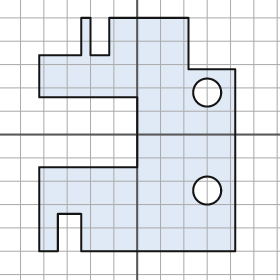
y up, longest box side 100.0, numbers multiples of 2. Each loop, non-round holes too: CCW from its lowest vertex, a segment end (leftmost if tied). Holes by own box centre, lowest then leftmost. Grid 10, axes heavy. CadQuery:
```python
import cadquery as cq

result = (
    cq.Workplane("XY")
    .moveTo(-42.0, -50.0)
    .lineTo(-34.0, -50.0)
    .lineTo(-34.0, -34.0)
    .lineTo(-24.0, -34.0)
    .lineTo(-24.0, -50.0)
    .lineTo(42.0, -50.0)
    .lineTo(42.0, 28.0)
    .lineTo(22.0, 28.0)
    .lineTo(22.0, 50.0)
    .lineTo(-12.0, 50.0)
    .lineTo(-12.0, 34.0)
    .lineTo(-20.0, 34.0)
    .lineTo(-20.0, 50.0)
    .lineTo(-24.0, 50.0)
    .lineTo(-24.0, 34.0)
    .lineTo(-42.0, 34.0)
    .lineTo(-42.0, 16.0)
    .lineTo(0.0, 16.0)
    .lineTo(0.0, -14.0)
    .lineTo(-42.0, -14.0)
    .close()
    .moveTo(30.0, -24.0)
    .circle(6.0)
    .moveTo(30.0, 18.0)
    .circle(6.0)
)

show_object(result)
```